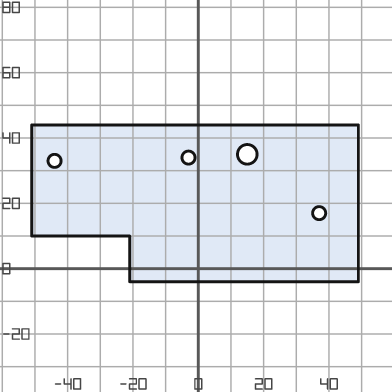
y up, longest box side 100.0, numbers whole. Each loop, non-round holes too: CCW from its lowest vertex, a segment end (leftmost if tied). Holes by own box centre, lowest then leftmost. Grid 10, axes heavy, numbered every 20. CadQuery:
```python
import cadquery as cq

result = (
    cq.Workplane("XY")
    .moveTo(-21.0, -4.0)
    .lineTo(49.0, -4.0)
    .lineTo(49.0, 44.0)
    .lineTo(-51.0, 44.0)
    .lineTo(-51.0, 10.0)
    .lineTo(-21.0, 10.0)
    .close()
    .moveTo(37.0, 17.0)
    .circle(2.0)
    .moveTo(-44.0, 33.0)
    .circle(2.0)
    .moveTo(-3.0, 34.0)
    .circle(2.0)
    .moveTo(15.0, 35.0)
    .circle(3.0)
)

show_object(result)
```